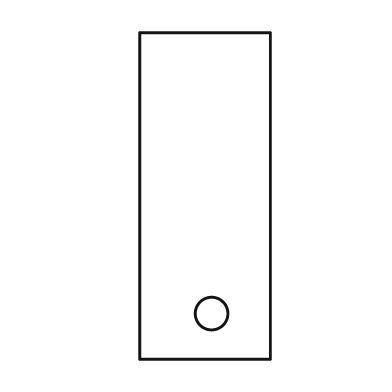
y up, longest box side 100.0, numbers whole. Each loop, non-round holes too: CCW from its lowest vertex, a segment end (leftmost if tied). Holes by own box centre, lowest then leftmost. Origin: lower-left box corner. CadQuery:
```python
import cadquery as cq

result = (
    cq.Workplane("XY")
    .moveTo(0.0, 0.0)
    .lineTo(40.0, 0.0)
    .lineTo(40.0, 100.0)
    .lineTo(0.0, 100.0)
    .close()
    .moveTo(22.0, 14.0)
    .circle(5.0)
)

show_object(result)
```